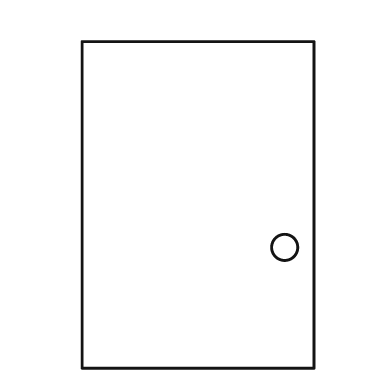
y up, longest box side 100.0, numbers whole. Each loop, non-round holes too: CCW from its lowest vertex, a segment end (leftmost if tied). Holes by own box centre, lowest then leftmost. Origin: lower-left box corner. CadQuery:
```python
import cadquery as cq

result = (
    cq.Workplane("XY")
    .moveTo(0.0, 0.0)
    .lineTo(71.0, 0.0)
    .lineTo(71.0, 100.0)
    .lineTo(0.0, 100.0)
    .close()
    .moveTo(62.0, 37.0)
    .circle(4.0)
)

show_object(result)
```